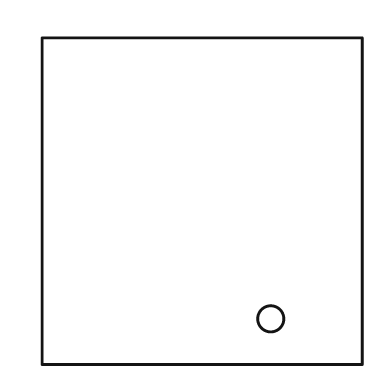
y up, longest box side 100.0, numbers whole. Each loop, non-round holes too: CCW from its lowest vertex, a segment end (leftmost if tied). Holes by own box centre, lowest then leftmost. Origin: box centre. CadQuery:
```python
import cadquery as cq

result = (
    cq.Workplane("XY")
    .moveTo(-49.0, -50.0)
    .lineTo(49.0, -50.0)
    .lineTo(49.0, 50.0)
    .lineTo(-49.0, 50.0)
    .close()
    .moveTo(21.0, -36.0)
    .circle(4.0)
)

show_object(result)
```